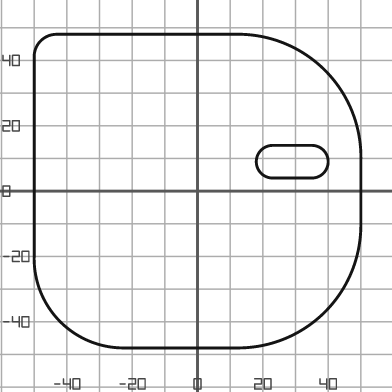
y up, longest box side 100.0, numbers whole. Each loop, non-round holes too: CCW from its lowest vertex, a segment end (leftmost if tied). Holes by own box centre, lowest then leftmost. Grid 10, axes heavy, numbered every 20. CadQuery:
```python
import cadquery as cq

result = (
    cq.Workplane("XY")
    .moveTo(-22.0, -48.0)
    .lineTo(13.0, -48.0)
    .threePointArc((39.0, -37.0), (50.0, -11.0))
    .lineTo(50.0, 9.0)
    .threePointArc((39.0, 37.0), (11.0, 48.0))
    .lineTo(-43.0, 48.0)
    .threePointArc((-48.0, 46.0), (-50.0, 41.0))
    .lineTo(-50.0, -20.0)
    .threePointArc((-42.0, -40.0), (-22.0, -48.0))
    .close()
    .moveTo(23.0, 4.0)
    .lineTo(35.0, 4.0)
    .threePointArc((40.0, 9.0), (35.0, 14.0))
    .lineTo(23.0, 14.0)
    .threePointArc((18.0, 9.0), (23.0, 4.0))
    .close()
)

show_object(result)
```